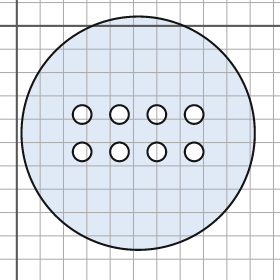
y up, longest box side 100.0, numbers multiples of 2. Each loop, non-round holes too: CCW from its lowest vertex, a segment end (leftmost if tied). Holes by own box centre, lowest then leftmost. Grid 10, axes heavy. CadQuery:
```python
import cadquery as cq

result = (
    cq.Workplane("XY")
    .moveTo(52.0, -46.0)
    .circle(50.0)
    .moveTo(28.0, -54.0)
    .circle(4.0)
    .moveTo(44.0, -54.0)
    .circle(4.0)
    .moveTo(60.0, -54.0)
    .circle(4.0)
    .moveTo(76.0, -54.0)
    .circle(4.0)
    .moveTo(28.0, -38.0)
    .circle(4.0)
    .moveTo(44.0, -38.0)
    .circle(4.0)
    .moveTo(60.0, -38.0)
    .circle(4.0)
    .moveTo(76.0, -38.0)
    .circle(4.0)
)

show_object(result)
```